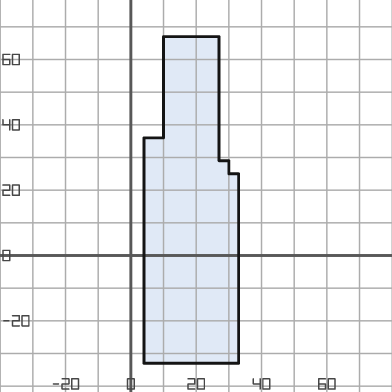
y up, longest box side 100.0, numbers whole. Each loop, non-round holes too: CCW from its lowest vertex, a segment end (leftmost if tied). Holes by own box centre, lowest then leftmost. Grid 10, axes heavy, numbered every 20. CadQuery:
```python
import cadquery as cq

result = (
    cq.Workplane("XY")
    .moveTo(4.0, -33.0)
    .lineTo(33.0, -33.0)
    .lineTo(33.0, 25.0)
    .lineTo(30.0, 25.0)
    .lineTo(30.0, 29.0)
    .lineTo(27.0, 29.0)
    .lineTo(27.0, 67.0)
    .lineTo(10.0, 67.0)
    .lineTo(10.0, 36.0)
    .lineTo(4.0, 36.0)
    .close()
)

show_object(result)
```